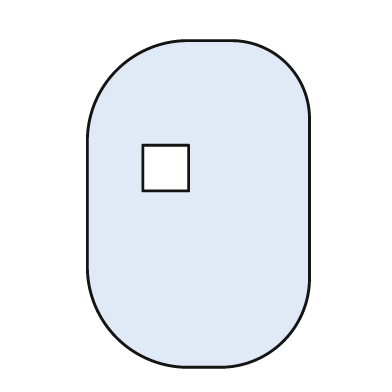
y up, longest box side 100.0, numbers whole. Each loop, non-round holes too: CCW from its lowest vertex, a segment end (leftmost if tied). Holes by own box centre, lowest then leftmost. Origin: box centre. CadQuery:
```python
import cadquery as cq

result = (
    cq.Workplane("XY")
    .moveTo(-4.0, -50.0)
    .lineTo(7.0, -50.0)
    .threePointArc((26.0, -42.0), (34.0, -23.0))
    .lineTo(34.0, 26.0)
    .threePointArc((27.0, 43.0), (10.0, 50.0))
    .lineTo(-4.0, 50.0)
    .threePointArc((-25.0, 41.0), (-34.0, 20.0))
    .lineTo(-34.0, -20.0)
    .threePointArc((-25.0, -41.0), (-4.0, -50.0))
    .close()
    .moveTo(-17.0, 4.0)
    .lineTo(-3.0, 4.0)
    .lineTo(-3.0, 18.0)
    .lineTo(-17.0, 18.0)
    .close()
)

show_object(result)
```